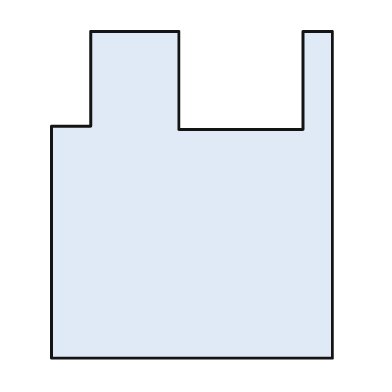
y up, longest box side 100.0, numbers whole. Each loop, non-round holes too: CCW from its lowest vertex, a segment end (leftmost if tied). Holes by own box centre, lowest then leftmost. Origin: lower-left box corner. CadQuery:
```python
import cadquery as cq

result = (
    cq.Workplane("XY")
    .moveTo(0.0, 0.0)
    .lineTo(86.0, 0.0)
    .lineTo(86.0, 100.0)
    .lineTo(77.0, 100.0)
    .lineTo(77.0, 70.0)
    .lineTo(39.0, 70.0)
    .lineTo(39.0, 100.0)
    .lineTo(12.0, 100.0)
    .lineTo(12.0, 71.0)
    .lineTo(0.0, 71.0)
    .close()
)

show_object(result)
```